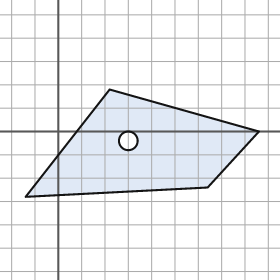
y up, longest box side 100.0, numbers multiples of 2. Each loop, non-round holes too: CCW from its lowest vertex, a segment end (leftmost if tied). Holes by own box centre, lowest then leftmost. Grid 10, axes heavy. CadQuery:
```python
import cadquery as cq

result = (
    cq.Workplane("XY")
    .moveTo(-14.0, -28.0)
    .lineTo(64.0, -24.0)
    .lineTo(86.0, 0.0)
    .lineTo(22.0, 18.0)
    .close()
    .moveTo(30.0, -4.0)
    .circle(4.0)
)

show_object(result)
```